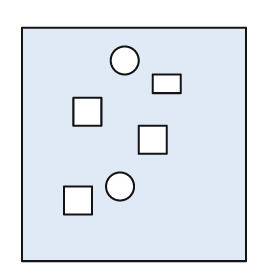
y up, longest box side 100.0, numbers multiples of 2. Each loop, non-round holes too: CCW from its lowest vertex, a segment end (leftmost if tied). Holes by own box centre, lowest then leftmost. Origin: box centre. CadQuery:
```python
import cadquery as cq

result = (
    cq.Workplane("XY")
    .moveTo(-48.0, -50.0)
    .lineTo(48.0, -50.0)
    .lineTo(48.0, 50.0)
    .lineTo(-48.0, 50.0)
    .close()
    .moveTo(-30.0, -30.0)
    .lineTo(-18.0, -30.0)
    .lineTo(-18.0, -18.0)
    .lineTo(-30.0, -18.0)
    .close()
    .moveTo(-6.0, -18.0)
    .circle(6.0)
    .moveTo(2.0, -4.0)
    .lineTo(14.0, -4.0)
    .lineTo(14.0, 8.0)
    .lineTo(2.0, 8.0)
    .close()
    .moveTo(-26.0, 8.0)
    .lineTo(-14.0, 8.0)
    .lineTo(-14.0, 20.0)
    .lineTo(-26.0, 20.0)
    .close()
    .moveTo(8.0, 22.0)
    .lineTo(20.0, 22.0)
    .lineTo(20.0, 30.0)
    .lineTo(8.0, 30.0)
    .close()
    .moveTo(-4.0, 36.0)
    .circle(6.0)
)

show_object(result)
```